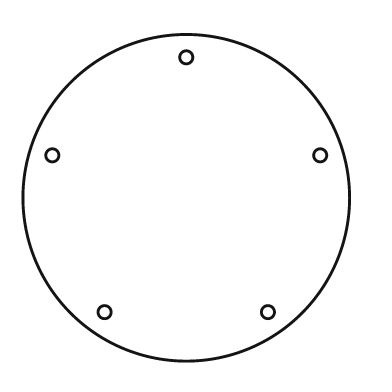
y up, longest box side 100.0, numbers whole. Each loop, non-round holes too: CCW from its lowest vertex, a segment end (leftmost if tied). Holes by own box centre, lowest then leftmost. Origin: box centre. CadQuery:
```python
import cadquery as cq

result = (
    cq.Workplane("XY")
    .moveTo(0.0, 0.0)
    .circle(50.0)
    .moveTo(-25.0, -35.0)
    .circle(2.0)
    .moveTo(25.0, -35.0)
    .circle(2.0)
    .moveTo(-41.0, 13.0)
    .circle(2.0)
    .moveTo(41.0, 13.0)
    .circle(2.0)
    .moveTo(0.0, 43.0)
    .circle(2.0)
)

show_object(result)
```